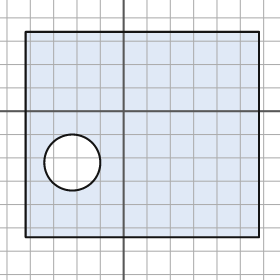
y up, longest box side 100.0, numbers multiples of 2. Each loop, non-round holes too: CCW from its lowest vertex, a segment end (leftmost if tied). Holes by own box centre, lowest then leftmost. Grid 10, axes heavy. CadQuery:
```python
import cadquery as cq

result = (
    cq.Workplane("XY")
    .moveTo(-42.0, -54.0)
    .lineTo(58.0, -54.0)
    .lineTo(58.0, 34.0)
    .lineTo(-42.0, 34.0)
    .close()
    .moveTo(-22.0, -22.0)
    .circle(12.0)
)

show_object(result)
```